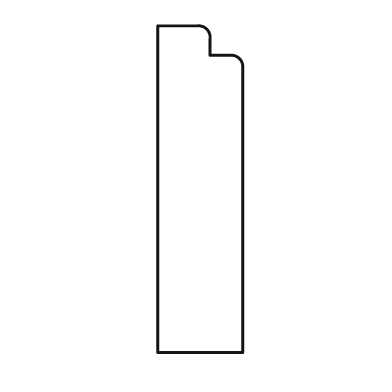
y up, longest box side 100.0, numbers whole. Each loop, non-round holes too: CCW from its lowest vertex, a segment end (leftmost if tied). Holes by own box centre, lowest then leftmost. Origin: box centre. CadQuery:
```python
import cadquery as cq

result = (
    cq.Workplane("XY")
    .moveTo(-13.0, -50.0)
    .lineTo(13.0, -50.0)
    .lineTo(13.0, 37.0)
    .threePointArc((12.0, 40.0), (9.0, 41.0))
    .lineTo(3.0, 41.0)
    .lineTo(3.0, 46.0)
    .threePointArc((2.0, 49.0), (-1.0, 50.0))
    .lineTo(-13.0, 50.0)
    .close()
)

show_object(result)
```